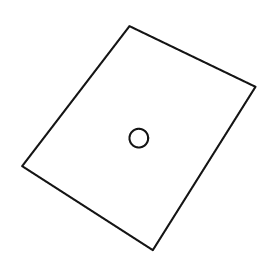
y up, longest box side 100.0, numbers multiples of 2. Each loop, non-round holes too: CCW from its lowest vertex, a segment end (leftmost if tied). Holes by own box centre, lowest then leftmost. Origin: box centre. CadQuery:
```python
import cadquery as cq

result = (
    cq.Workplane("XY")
    .moveTo(6.0, -48.0)
    .lineTo(50.0, 22.0)
    .lineTo(-4.0, 48.0)
    .lineTo(-50.0, -12.0)
    .close()
    .moveTo(0.0, 0.0)
    .circle(4.0)
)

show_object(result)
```